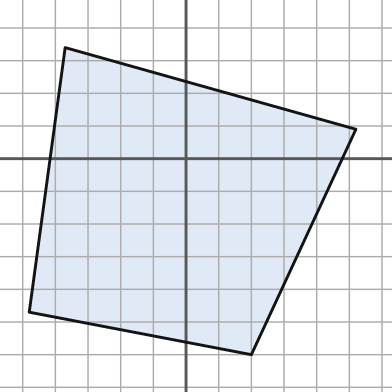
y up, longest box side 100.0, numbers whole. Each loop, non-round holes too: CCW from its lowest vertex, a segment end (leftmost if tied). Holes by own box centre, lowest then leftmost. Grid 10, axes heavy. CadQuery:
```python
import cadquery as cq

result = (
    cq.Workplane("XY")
    .moveTo(20.0, -60.0)
    .lineTo(52.0, 9.0)
    .lineTo(-37.0, 34.0)
    .lineTo(-48.0, -47.0)
    .close()
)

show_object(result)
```